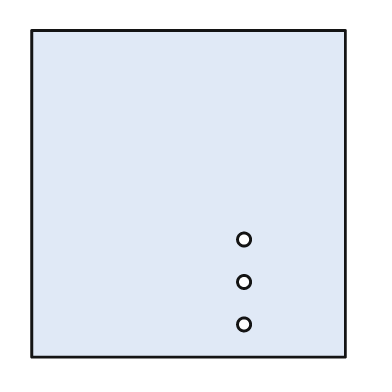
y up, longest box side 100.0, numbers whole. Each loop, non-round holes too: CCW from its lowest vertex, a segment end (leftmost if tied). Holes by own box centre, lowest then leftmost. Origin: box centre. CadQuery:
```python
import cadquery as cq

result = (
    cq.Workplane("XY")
    .moveTo(-48.0, -50.0)
    .lineTo(48.0, -50.0)
    .lineTo(48.0, 50.0)
    .lineTo(-48.0, 50.0)
    .close()
    .moveTo(17.0, -40.0)
    .circle(2.0)
    .moveTo(17.0, -27.0)
    .circle(2.0)
    .moveTo(17.0, -14.0)
    .circle(2.0)
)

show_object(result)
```